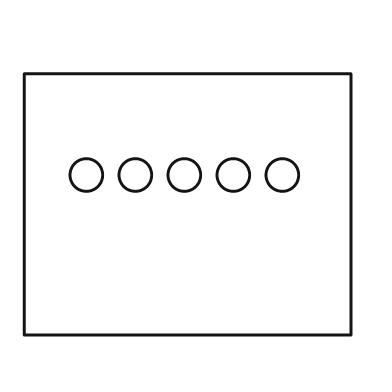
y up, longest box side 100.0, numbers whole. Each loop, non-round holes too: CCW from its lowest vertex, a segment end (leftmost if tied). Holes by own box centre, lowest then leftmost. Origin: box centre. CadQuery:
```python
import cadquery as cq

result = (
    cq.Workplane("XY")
    .moveTo(-50.0, -40.0)
    .lineTo(50.0, -40.0)
    .lineTo(50.0, 40.0)
    .lineTo(-50.0, 40.0)
    .close()
    .moveTo(-31.0, 9.0)
    .circle(5.0)
    .moveTo(-16.0, 9.0)
    .circle(5.0)
    .moveTo(-1.0, 9.0)
    .circle(5.0)
    .moveTo(14.0, 9.0)
    .circle(5.0)
    .moveTo(29.0, 9.0)
    .circle(5.0)
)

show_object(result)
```